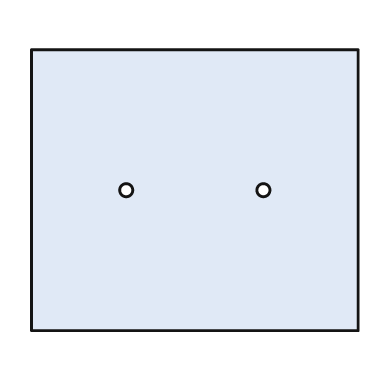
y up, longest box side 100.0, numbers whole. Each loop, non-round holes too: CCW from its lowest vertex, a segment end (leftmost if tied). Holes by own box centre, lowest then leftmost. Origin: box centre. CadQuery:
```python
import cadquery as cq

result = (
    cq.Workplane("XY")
    .moveTo(-50.0, -43.0)
    .lineTo(50.0, -43.0)
    .lineTo(50.0, 43.0)
    .lineTo(-50.0, 43.0)
    .close()
    .moveTo(-21.0, 0.0)
    .circle(2.0)
    .moveTo(21.0, 0.0)
    .circle(2.0)
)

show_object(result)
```